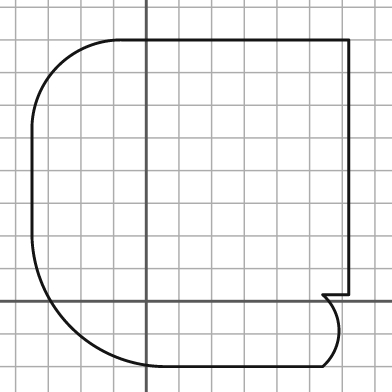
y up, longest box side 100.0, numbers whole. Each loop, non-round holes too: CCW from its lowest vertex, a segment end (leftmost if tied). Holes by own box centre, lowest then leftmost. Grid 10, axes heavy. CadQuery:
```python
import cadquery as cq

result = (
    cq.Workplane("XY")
    .moveTo(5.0, -20.0)
    .lineTo(54.0, -20.0)
    .threePointArc((59.0, -9.0), (54.0, 2.0))
    .lineTo(62.0, 2.0)
    .lineTo(62.0, 80.0)
    .lineTo(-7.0, 80.0)
    .threePointArc((-27.0, 72.0), (-35.0, 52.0))
    .lineTo(-35.0, 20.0)
    .threePointArc((-23.0, -8.0), (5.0, -20.0))
    .close()
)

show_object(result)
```